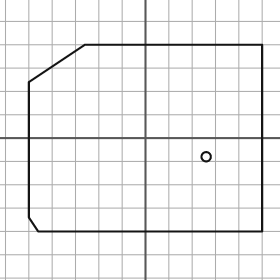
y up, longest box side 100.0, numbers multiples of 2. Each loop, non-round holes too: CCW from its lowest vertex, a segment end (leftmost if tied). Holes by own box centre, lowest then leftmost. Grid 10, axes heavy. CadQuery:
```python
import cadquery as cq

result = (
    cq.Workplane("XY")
    .moveTo(-46.0, -40.0)
    .lineTo(50.0, -40.0)
    .lineTo(50.0, 40.0)
    .lineTo(-26.0, 40.0)
    .lineTo(-50.0, 24.0)
    .lineTo(-50.0, -34.0)
    .close()
    .moveTo(26.0, -8.0)
    .circle(2.0)
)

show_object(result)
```